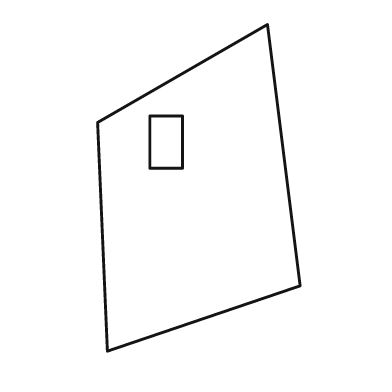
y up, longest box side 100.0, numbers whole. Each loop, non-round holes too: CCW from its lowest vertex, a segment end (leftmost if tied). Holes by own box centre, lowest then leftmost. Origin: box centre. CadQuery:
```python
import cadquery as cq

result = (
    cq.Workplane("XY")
    .moveTo(-28.0, -50.0)
    .lineTo(31.0, -30.0)
    .lineTo(21.0, 50.0)
    .lineTo(-31.0, 20.0)
    .close()
    .moveTo(-15.0, 6.0)
    .lineTo(-5.0, 6.0)
    .lineTo(-5.0, 22.0)
    .lineTo(-15.0, 22.0)
    .close()
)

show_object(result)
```